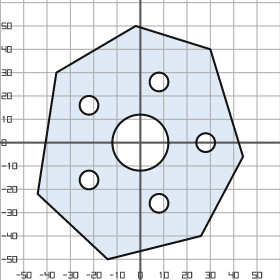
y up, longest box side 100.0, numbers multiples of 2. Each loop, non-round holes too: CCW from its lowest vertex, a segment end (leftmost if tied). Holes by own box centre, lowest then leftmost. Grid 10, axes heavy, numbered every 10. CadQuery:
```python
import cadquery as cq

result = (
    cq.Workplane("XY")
    .moveTo(-14.0, -50.0)
    .lineTo(26.0, -40.0)
    .lineTo(44.0, -6.0)
    .lineTo(30.0, 40.0)
    .lineTo(-2.0, 50.0)
    .lineTo(-36.0, 30.0)
    .lineTo(-44.0, -22.0)
    .close()
    .moveTo(8.0, -26.0)
    .circle(4.0)
    .moveTo(-22.0, -16.0)
    .circle(4.0)
    .moveTo(0.0, 0.0)
    .circle(12.0)
    .moveTo(28.0, 0.0)
    .circle(4.0)
    .moveTo(-22.0, 16.0)
    .circle(4.0)
    .moveTo(8.0, 26.0)
    .circle(4.0)
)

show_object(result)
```